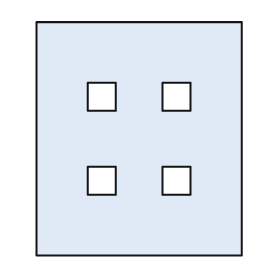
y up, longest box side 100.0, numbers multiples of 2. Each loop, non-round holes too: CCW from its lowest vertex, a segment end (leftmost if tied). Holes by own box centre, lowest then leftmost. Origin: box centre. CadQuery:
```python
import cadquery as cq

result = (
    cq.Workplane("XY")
    .moveTo(-44.0, -50.0)
    .lineTo(44.0, -50.0)
    .lineTo(44.0, 50.0)
    .lineTo(-44.0, 50.0)
    .close()
    .moveTo(-22.0, -24.0)
    .lineTo(-10.0, -24.0)
    .lineTo(-10.0, -12.0)
    .lineTo(-22.0, -12.0)
    .close()
    .moveTo(10.0, -24.0)
    .lineTo(22.0, -24.0)
    .lineTo(22.0, -12.0)
    .lineTo(10.0, -12.0)
    .close()
    .moveTo(-22.0, 12.0)
    .lineTo(-10.0, 12.0)
    .lineTo(-10.0, 24.0)
    .lineTo(-22.0, 24.0)
    .close()
    .moveTo(10.0, 12.0)
    .lineTo(22.0, 12.0)
    .lineTo(22.0, 24.0)
    .lineTo(10.0, 24.0)
    .close()
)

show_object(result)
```